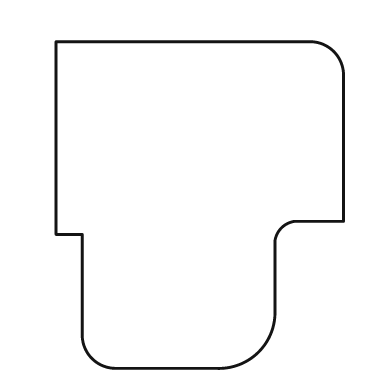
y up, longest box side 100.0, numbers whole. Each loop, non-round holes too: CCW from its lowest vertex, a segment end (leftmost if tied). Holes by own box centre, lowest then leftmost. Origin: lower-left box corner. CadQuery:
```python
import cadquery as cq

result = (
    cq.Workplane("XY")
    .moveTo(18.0, 0.0)
    .lineTo(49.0, 0.0)
    .threePointArc((62.0, 5.0), (67.0, 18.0))
    .lineTo(67.0, 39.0)
    .threePointArc((69.0, 43.0), (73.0, 45.0))
    .lineTo(88.0, 45.0)
    .lineTo(88.0, 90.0)
    .threePointArc((85.0, 97.0), (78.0, 100.0))
    .lineTo(0.0, 100.0)
    .lineTo(0.0, 41.0)
    .lineTo(8.0, 41.0)
    .lineTo(8.0, 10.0)
    .threePointArc((11.0, 3.0), (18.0, 0.0))
    .close()
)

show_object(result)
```